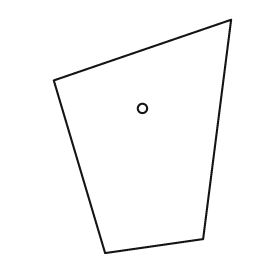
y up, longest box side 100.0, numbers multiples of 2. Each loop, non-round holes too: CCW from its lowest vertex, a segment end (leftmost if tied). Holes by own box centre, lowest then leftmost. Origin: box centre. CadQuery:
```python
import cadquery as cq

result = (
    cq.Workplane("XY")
    .moveTo(-16.0, -50.0)
    .lineTo(26.0, -44.0)
    .lineTo(38.0, 50.0)
    .lineTo(-38.0, 24.0)
    .close()
    .moveTo(0.0, 12.0)
    .circle(2.0)
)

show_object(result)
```